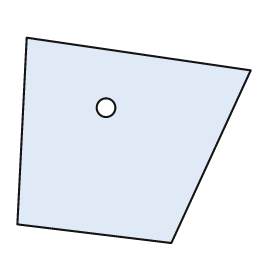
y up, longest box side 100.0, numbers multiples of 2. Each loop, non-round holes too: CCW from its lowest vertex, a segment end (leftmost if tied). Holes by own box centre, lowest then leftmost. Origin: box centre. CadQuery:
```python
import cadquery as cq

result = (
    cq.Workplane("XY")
    .moveTo(16.0, -44.0)
    .lineTo(50.0, 30.0)
    .lineTo(-46.0, 44.0)
    .lineTo(-50.0, -36.0)
    .close()
    .moveTo(-12.0, 14.0)
    .circle(4.0)
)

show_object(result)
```